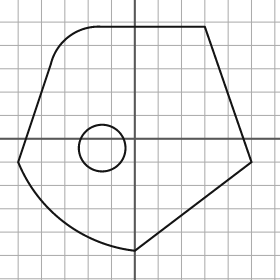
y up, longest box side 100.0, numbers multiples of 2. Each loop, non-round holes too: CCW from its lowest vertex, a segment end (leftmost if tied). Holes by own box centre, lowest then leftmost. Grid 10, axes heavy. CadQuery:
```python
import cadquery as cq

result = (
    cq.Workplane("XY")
    .moveTo(0.0, -48.0)
    .lineTo(50.0, -10.0)
    .lineTo(30.0, 48.0)
    .lineTo(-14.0, 48.0)
    .threePointArc((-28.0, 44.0), (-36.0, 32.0))
    .lineTo(-50.0, -10.0)
    .threePointArc((-30.0, -36.0), (0.0, -48.0))
    .close()
    .moveTo(-14.0, -4.0)
    .circle(10.0)
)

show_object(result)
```